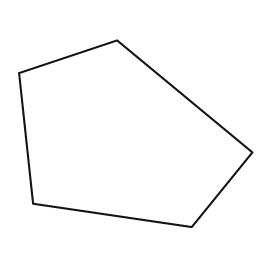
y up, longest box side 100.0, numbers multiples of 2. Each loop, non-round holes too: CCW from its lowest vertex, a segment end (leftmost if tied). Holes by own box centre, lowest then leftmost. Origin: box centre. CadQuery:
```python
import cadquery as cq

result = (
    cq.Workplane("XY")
    .moveTo(24.0, -40.0)
    .lineTo(50.0, -8.0)
    .lineTo(-8.0, 40.0)
    .lineTo(-50.0, 26.0)
    .lineTo(-44.0, -30.0)
    .close()
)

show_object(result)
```